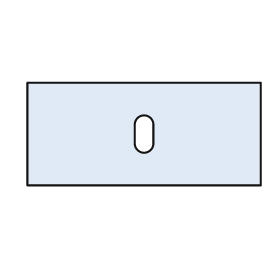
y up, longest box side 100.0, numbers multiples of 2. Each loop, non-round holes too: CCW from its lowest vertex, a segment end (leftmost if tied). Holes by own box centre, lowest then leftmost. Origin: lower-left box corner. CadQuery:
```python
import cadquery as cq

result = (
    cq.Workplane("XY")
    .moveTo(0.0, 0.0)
    .lineTo(100.0, 0.0)
    .lineTo(100.0, 44.0)
    .lineTo(0.0, 44.0)
    .close()
    .moveTo(46.0, 18.0)
    .threePointArc((50.0, 14.0), (54.0, 18.0))
    .lineTo(54.0, 26.0)
    .threePointArc((50.0, 30.0), (46.0, 26.0))
    .close()
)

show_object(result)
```